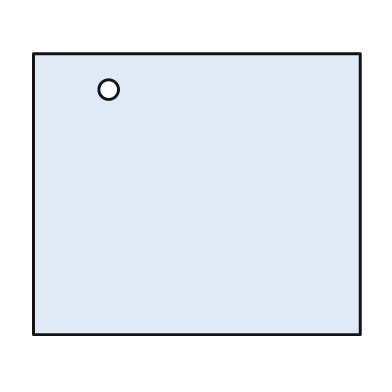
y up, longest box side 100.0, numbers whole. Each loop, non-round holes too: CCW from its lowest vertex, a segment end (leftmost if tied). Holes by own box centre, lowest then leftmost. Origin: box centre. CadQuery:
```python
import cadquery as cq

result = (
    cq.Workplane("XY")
    .moveTo(-50.0, -43.0)
    .lineTo(50.0, -43.0)
    .lineTo(50.0, 43.0)
    .lineTo(-50.0, 43.0)
    .close()
    .moveTo(-27.0, 32.0)
    .circle(3.0)
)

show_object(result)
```